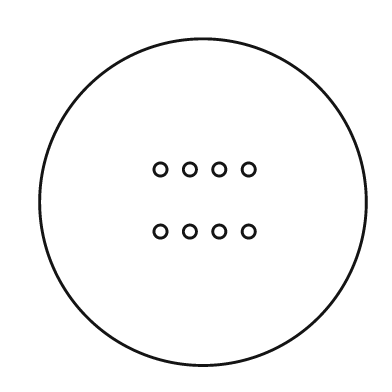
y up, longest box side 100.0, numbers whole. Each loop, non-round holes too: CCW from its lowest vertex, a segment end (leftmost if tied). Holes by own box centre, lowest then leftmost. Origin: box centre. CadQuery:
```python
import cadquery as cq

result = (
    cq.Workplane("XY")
    .moveTo(0.0, 0.0)
    .circle(50.0)
    .moveTo(-13.0, -9.0)
    .circle(2.0)
    .moveTo(-4.0, -9.0)
    .circle(2.0)
    .moveTo(5.0, -9.0)
    .circle(2.0)
    .moveTo(14.0, -9.0)
    .circle(2.0)
    .moveTo(-13.0, 10.0)
    .circle(2.0)
    .moveTo(-4.0, 10.0)
    .circle(2.0)
    .moveTo(5.0, 10.0)
    .circle(2.0)
    .moveTo(14.0, 10.0)
    .circle(2.0)
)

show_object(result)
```